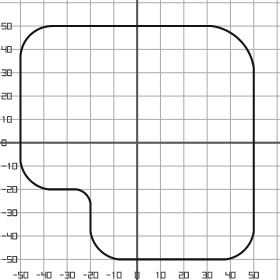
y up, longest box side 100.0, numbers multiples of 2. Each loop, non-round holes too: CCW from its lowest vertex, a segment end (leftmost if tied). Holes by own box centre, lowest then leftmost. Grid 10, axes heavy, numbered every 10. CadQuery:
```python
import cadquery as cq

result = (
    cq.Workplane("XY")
    .moveTo(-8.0, -50.0)
    .lineTo(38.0, -50.0)
    .threePointArc((46.0, -46.0), (50.0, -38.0))
    .lineTo(50.0, 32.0)
    .threePointArc((44.0, 44.0), (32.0, 50.0))
    .lineTo(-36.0, 50.0)
    .threePointArc((-46.0, 46.0), (-50.0, 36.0))
    .lineTo(-50.0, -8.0)
    .threePointArc((-46.0, -16.0), (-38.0, -20.0))
    .lineTo(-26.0, -20.0)
    .threePointArc((-22.0, -22.0), (-20.0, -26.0))
    .lineTo(-20.0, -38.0)
    .threePointArc((-16.0, -46.0), (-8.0, -50.0))
    .close()
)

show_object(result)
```